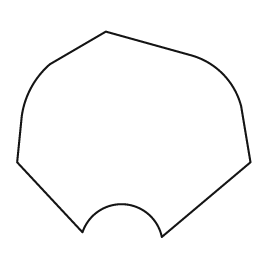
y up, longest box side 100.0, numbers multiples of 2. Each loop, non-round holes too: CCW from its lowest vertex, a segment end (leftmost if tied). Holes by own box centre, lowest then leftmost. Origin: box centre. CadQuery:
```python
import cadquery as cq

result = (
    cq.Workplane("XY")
    .moveTo(12.0, -44.0)
    .lineTo(50.0, -12.0)
    .lineTo(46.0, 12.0)
    .threePointArc((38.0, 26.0), (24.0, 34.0))
    .lineTo(-12.0, 44.0)
    .lineTo(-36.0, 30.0)
    .threePointArc((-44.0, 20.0), (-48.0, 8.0))
    .lineTo(-50.0, -12.0)
    .lineTo(-22.0, -42.0)
    .threePointArc((-4.0, -30.0), (12.0, -44.0))
    .close()
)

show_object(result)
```